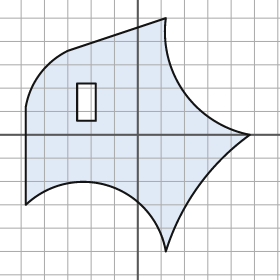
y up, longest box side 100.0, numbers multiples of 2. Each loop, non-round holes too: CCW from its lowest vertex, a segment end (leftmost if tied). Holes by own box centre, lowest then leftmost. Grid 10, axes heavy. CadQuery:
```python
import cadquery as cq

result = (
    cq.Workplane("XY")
    .moveTo(12.0, -50.0)
    .threePointArc((26.0, -22.0), (48.0, 0.0))
    .threePointArc((20.0, 18.0), (12.0, 50.0))
    .lineTo(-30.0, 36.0)
    .threePointArc((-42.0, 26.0), (-48.0, 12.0))
    .lineTo(-48.0, -30.0)
    .threePointArc((-12.0, -22.0), (12.0, -50.0))
    .close()
    .moveTo(-26.0, 6.0)
    .lineTo(-18.0, 6.0)
    .lineTo(-18.0, 22.0)
    .lineTo(-26.0, 22.0)
    .close()
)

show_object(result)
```